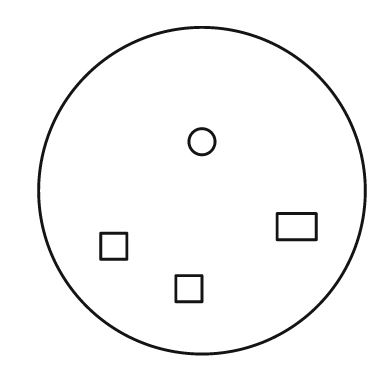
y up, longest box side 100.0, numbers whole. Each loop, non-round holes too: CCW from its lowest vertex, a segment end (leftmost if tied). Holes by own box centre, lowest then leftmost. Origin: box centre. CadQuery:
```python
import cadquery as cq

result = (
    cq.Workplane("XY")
    .moveTo(0.0, 0.0)
    .circle(50.0)
    .moveTo(-8.0, -34.0)
    .lineTo(0.0, -34.0)
    .lineTo(0.0, -26.0)
    .lineTo(-8.0, -26.0)
    .close()
    .moveTo(-31.0, -21.0)
    .lineTo(-23.0, -21.0)
    .lineTo(-23.0, -13.0)
    .lineTo(-31.0, -13.0)
    .close()
    .moveTo(23.0, -15.0)
    .lineTo(35.0, -15.0)
    .lineTo(35.0, -7.0)
    .lineTo(23.0, -7.0)
    .close()
    .moveTo(0.0, 15.0)
    .circle(4.0)
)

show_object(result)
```